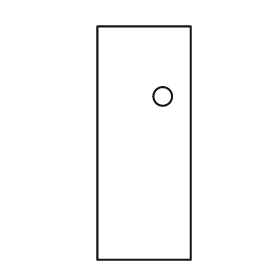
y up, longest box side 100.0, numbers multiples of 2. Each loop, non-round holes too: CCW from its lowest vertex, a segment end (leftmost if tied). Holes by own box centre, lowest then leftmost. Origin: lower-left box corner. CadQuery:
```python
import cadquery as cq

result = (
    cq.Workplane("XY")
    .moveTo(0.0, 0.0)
    .lineTo(40.0, 0.0)
    .lineTo(40.0, 100.0)
    .lineTo(0.0, 100.0)
    .close()
    .moveTo(28.0, 70.0)
    .circle(4.0)
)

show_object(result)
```